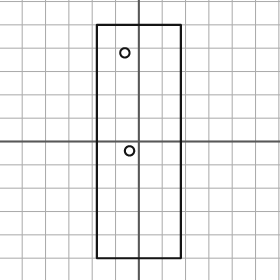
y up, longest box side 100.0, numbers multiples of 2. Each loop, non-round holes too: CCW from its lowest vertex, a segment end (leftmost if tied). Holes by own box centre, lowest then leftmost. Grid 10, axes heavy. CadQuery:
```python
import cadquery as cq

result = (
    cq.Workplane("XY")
    .moveTo(-18.0, -50.0)
    .lineTo(18.0, -50.0)
    .lineTo(18.0, 50.0)
    .lineTo(-18.0, 50.0)
    .close()
    .moveTo(-4.0, -4.0)
    .circle(2.0)
    .moveTo(-6.0, 38.0)
    .circle(2.0)
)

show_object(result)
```